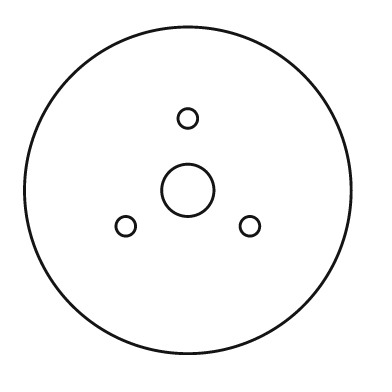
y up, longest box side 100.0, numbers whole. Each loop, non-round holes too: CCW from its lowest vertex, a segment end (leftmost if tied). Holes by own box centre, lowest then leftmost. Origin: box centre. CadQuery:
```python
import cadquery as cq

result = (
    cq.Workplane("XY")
    .moveTo(0.0, 0.0)
    .circle(50.0)
    .moveTo(-19.0, -11.0)
    .circle(3.0)
    .moveTo(19.0, -11.0)
    .circle(3.0)
    .moveTo(0.0, 0.0)
    .circle(8.0)
    .moveTo(0.0, 22.0)
    .circle(3.0)
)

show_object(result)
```